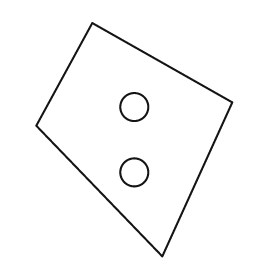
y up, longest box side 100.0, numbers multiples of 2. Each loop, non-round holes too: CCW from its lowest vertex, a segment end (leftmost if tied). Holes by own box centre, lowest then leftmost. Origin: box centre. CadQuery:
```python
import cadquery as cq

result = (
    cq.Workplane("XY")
    .moveTo(12.0, -50.0)
    .lineTo(42.0, 16.0)
    .lineTo(-18.0, 50.0)
    .lineTo(-42.0, 6.0)
    .close()
    .moveTo(0.0, -14.0)
    .circle(6.0)
    .moveTo(0.0, 14.0)
    .circle(6.0)
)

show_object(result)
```